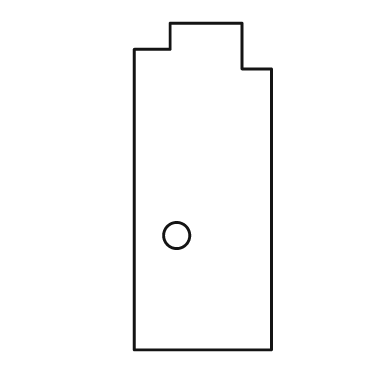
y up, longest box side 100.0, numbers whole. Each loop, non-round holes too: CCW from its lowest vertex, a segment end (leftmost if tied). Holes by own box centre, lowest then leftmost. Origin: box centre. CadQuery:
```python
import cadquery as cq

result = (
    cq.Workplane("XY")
    .moveTo(-21.0, -50.0)
    .lineTo(21.0, -50.0)
    .lineTo(21.0, 36.0)
    .lineTo(12.0, 36.0)
    .lineTo(12.0, 50.0)
    .lineTo(-10.0, 50.0)
    .lineTo(-10.0, 42.0)
    .lineTo(-21.0, 42.0)
    .close()
    .moveTo(-8.0, -15.0)
    .circle(4.0)
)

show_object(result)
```